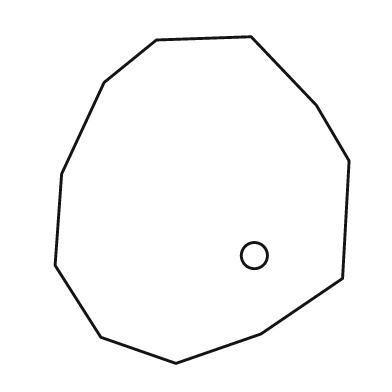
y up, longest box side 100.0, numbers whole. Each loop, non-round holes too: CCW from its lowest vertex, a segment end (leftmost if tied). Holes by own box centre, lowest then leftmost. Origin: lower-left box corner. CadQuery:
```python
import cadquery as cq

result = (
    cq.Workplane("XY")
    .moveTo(37.0, 0.0)
    .lineTo(63.0, 9.0)
    .lineTo(88.0, 26.0)
    .lineTo(90.0, 62.0)
    .lineTo(80.0, 79.0)
    .lineTo(60.0, 100.0)
    .lineTo(31.0, 99.0)
    .lineTo(15.0, 86.0)
    .lineTo(2.0, 58.0)
    .lineTo(0.0, 30.0)
    .lineTo(14.0, 8.0)
    .close()
    .moveTo(61.0, 33.0)
    .circle(4.0)
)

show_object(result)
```